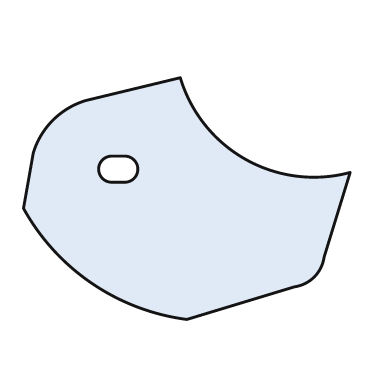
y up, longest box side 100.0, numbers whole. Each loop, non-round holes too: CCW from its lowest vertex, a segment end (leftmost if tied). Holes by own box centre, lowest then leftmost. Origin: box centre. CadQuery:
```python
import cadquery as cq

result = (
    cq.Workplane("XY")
    .moveTo(0.0, -37.0)
    .lineTo(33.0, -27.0)
    .threePointArc((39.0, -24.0), (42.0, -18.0))
    .lineTo(50.0, 8.0)
    .threePointArc((18.0, 12.0), (-2.0, 37.0))
    .lineTo(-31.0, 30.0)
    .threePointArc((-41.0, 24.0), (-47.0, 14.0))
    .lineTo(-50.0, -3.0)
    .threePointArc((-29.0, -26.0), (0.0, -37.0))
    .close()
    .moveTo(-23.0, 5.0)
    .lineTo(-19.0, 5.0)
    .threePointArc((-15.0, 9.0), (-19.0, 13.0))
    .lineTo(-23.0, 13.0)
    .threePointArc((-27.0, 9.0), (-23.0, 5.0))
    .close()
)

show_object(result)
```